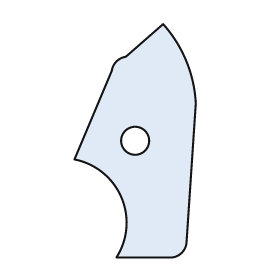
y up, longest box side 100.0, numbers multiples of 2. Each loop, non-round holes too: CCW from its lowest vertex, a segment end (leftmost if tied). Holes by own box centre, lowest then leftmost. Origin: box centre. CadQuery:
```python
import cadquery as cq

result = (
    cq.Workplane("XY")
    .moveTo(-8.0, -50.0)
    .lineTo(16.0, -50.0)
    .threePointArc((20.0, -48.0), (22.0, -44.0))
    .lineTo(26.0, 16.0)
    .threePointArc((22.0, 34.0), (12.0, 50.0))
    .lineTo(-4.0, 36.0)
    .threePointArc((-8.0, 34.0), (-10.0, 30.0))
    .lineTo(-26.0, -8.0)
    .threePointArc((-6.0, -24.0), (-8.0, -50.0))
    .close()
    .moveTo(0.0, 0.0)
    .circle(6.0)
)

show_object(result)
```